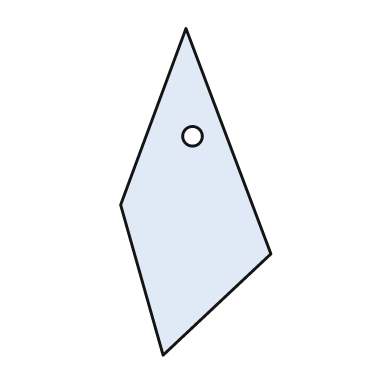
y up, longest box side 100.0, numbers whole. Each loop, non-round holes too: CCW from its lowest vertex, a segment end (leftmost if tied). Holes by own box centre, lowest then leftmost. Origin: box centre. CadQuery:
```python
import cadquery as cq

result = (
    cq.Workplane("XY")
    .moveTo(-10.0, -50.0)
    .lineTo(23.0, -19.0)
    .lineTo(-3.0, 50.0)
    .lineTo(-23.0, -4.0)
    .close()
    .moveTo(-1.0, 17.0)
    .circle(3.0)
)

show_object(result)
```